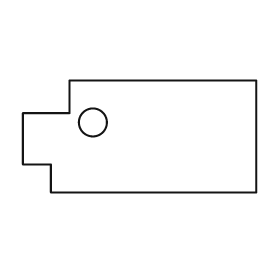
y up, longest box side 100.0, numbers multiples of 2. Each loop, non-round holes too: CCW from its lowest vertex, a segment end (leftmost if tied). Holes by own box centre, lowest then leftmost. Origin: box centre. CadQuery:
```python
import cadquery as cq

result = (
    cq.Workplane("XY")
    .moveTo(-38.0, -24.0)
    .lineTo(50.0, -24.0)
    .lineTo(50.0, 24.0)
    .lineTo(-30.0, 24.0)
    .lineTo(-30.0, 10.0)
    .lineTo(-50.0, 10.0)
    .lineTo(-50.0, -12.0)
    .lineTo(-38.0, -12.0)
    .close()
    .moveTo(-20.0, 6.0)
    .circle(6.0)
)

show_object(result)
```